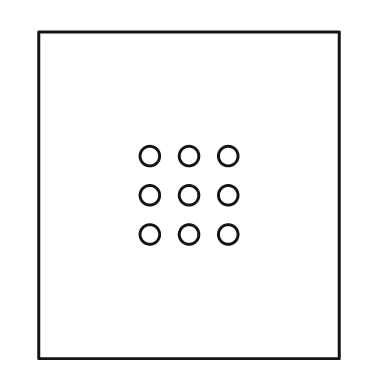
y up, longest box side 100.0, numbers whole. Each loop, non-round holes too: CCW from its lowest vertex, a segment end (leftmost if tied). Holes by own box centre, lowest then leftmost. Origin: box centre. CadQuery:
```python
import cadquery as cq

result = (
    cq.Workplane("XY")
    .moveTo(-46.0, -50.0)
    .lineTo(46.0, -50.0)
    .lineTo(46.0, 50.0)
    .lineTo(-46.0, 50.0)
    .close()
    .moveTo(-12.0, -12.0)
    .circle(3.0)
    .moveTo(0.0, -12.0)
    .circle(3.0)
    .moveTo(12.0, -12.0)
    .circle(3.0)
    .moveTo(-12.0, 0.0)
    .circle(3.0)
    .moveTo(0.0, 0.0)
    .circle(3.0)
    .moveTo(12.0, 0.0)
    .circle(3.0)
    .moveTo(-12.0, 12.0)
    .circle(3.0)
    .moveTo(0.0, 12.0)
    .circle(3.0)
    .moveTo(12.0, 12.0)
    .circle(3.0)
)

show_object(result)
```